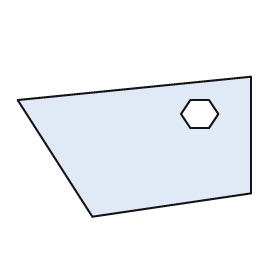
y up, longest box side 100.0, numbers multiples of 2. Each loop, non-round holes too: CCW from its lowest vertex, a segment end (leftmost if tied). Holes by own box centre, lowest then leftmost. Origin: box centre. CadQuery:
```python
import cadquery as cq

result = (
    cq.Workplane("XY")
    .moveTo(-18.0, -30.0)
    .lineTo(50.0, -20.0)
    .lineTo(50.0, 30.0)
    .lineTo(-50.0, 20.0)
    .close()
    .moveTo(24.0, 8.0)
    .lineTo(32.0, 8.0)
    .lineTo(36.0, 14.0)
    .lineTo(32.0, 20.0)
    .lineTo(24.0, 20.0)
    .lineTo(20.0, 14.0)
    .close()
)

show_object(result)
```